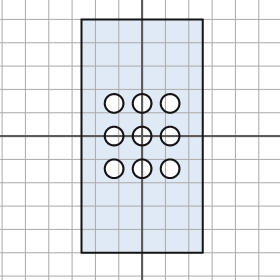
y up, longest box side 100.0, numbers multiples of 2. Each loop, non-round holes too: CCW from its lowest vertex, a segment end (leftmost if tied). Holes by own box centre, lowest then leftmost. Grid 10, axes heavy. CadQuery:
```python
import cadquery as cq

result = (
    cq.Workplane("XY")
    .moveTo(-26.0, -50.0)
    .lineTo(26.0, -50.0)
    .lineTo(26.0, 50.0)
    .lineTo(-26.0, 50.0)
    .close()
    .moveTo(-12.0, -14.0)
    .circle(4.0)
    .moveTo(0.0, -14.0)
    .circle(4.0)
    .moveTo(12.0, -14.0)
    .circle(4.0)
    .moveTo(-12.0, 0.0)
    .circle(4.0)
    .moveTo(0.0, 0.0)
    .circle(4.0)
    .moveTo(12.0, 0.0)
    .circle(4.0)
    .moveTo(-12.0, 14.0)
    .circle(4.0)
    .moveTo(0.0, 14.0)
    .circle(4.0)
    .moveTo(12.0, 14.0)
    .circle(4.0)
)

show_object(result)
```